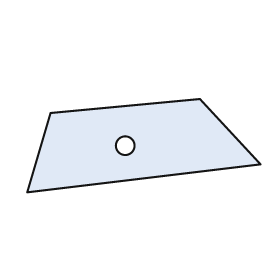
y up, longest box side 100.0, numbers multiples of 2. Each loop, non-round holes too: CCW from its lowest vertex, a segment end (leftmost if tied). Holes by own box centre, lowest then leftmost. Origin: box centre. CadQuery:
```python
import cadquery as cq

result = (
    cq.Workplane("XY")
    .moveTo(-50.0, -20.0)
    .lineTo(50.0, -8.0)
    .lineTo(24.0, 20.0)
    .lineTo(-40.0, 14.0)
    .close()
    .moveTo(-8.0, 0.0)
    .circle(4.0)
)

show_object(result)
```